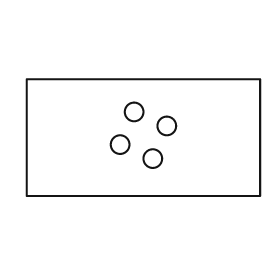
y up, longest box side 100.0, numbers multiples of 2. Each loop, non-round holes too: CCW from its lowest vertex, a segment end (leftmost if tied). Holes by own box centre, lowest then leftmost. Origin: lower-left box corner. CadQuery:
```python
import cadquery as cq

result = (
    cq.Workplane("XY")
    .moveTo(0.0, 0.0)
    .lineTo(100.0, 0.0)
    .lineTo(100.0, 50.0)
    .lineTo(0.0, 50.0)
    .close()
    .moveTo(54.0, 16.0)
    .circle(4.0)
    .moveTo(40.0, 22.0)
    .circle(4.0)
    .moveTo(60.0, 30.0)
    .circle(4.0)
    .moveTo(46.0, 36.0)
    .circle(4.0)
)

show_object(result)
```